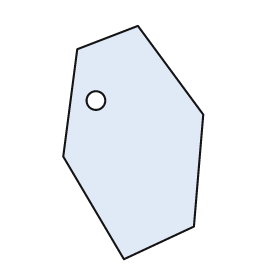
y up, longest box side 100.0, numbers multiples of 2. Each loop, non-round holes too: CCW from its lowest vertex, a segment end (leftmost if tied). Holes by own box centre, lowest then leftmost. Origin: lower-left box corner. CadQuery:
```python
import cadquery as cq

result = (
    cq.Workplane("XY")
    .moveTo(26.0, 0.0)
    .lineTo(56.0, 14.0)
    .lineTo(60.0, 62.0)
    .lineTo(32.0, 100.0)
    .lineTo(6.0, 90.0)
    .lineTo(0.0, 44.0)
    .close()
    .moveTo(14.0, 68.0)
    .circle(4.0)
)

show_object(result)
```